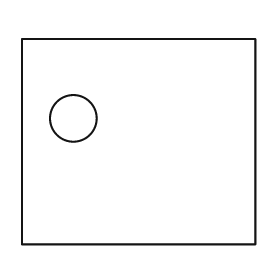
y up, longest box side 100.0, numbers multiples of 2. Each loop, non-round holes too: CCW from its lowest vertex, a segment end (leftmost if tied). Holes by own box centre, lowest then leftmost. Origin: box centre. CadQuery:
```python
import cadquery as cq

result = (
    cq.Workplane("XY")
    .moveTo(-50.0, -44.0)
    .lineTo(50.0, -44.0)
    .lineTo(50.0, 44.0)
    .lineTo(-50.0, 44.0)
    .close()
    .moveTo(-28.0, 10.0)
    .circle(10.0)
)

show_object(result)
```